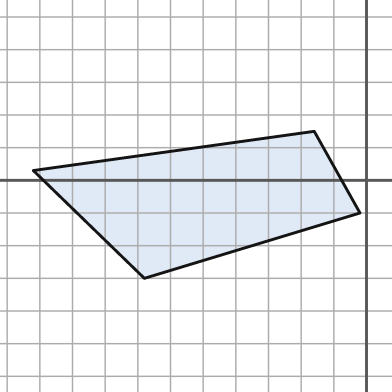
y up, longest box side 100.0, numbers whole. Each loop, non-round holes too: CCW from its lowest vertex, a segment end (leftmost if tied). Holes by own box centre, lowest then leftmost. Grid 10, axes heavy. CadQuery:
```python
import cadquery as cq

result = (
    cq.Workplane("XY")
    .moveTo(-68.0, -30.0)
    .lineTo(-2.0, -10.0)
    .lineTo(-16.0, 15.0)
    .lineTo(-102.0, 3.0)
    .close()
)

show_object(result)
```